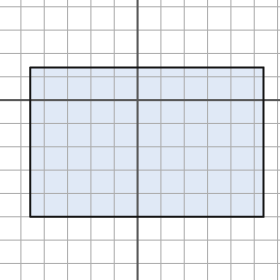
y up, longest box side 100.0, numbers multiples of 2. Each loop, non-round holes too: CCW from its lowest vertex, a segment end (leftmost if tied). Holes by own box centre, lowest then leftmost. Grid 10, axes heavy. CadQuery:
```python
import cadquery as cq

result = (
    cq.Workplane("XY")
    .moveTo(-46.0, -50.0)
    .lineTo(54.0, -50.0)
    .lineTo(54.0, 14.0)
    .lineTo(-46.0, 14.0)
    .close()
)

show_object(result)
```